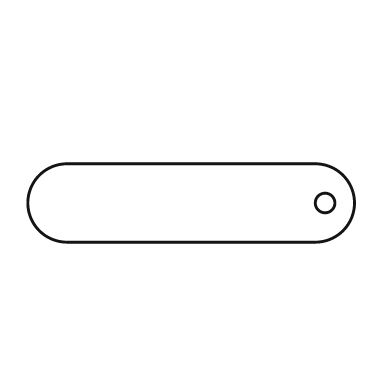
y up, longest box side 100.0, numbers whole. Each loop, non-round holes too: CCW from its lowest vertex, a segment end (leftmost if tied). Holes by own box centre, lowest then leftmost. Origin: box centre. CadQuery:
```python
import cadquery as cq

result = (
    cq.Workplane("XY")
    .moveTo(-38.0, -12.0)
    .lineTo(38.0, -12.0)
    .threePointArc((50.0, 0.0), (38.0, 12.0))
    .lineTo(-38.0, 12.0)
    .threePointArc((-50.0, 0.0), (-38.0, -12.0))
    .close()
    .moveTo(41.0, 0.0)
    .circle(3.0)
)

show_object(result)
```